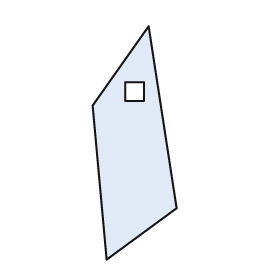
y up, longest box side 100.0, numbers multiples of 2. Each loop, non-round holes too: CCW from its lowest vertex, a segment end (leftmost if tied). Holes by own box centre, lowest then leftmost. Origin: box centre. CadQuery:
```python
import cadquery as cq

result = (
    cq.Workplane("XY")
    .moveTo(-12.0, -50.0)
    .lineTo(18.0, -28.0)
    .lineTo(6.0, 50.0)
    .lineTo(-18.0, 16.0)
    .close()
    .moveTo(-4.0, 18.0)
    .lineTo(4.0, 18.0)
    .lineTo(4.0, 26.0)
    .lineTo(-4.0, 26.0)
    .close()
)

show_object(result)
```